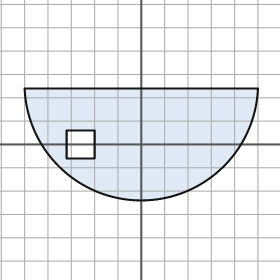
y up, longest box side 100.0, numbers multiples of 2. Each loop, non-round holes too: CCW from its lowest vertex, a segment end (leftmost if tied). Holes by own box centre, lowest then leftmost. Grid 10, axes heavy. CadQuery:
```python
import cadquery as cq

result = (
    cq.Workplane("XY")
    .moveTo(-50.0, 24.0)
    .threePointArc((0.0, -24.0), (50.0, 24.0))
    .close()
    .moveTo(-32.0, -6.0)
    .lineTo(-20.0, -6.0)
    .lineTo(-20.0, 6.0)
    .lineTo(-32.0, 6.0)
    .close()
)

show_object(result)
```